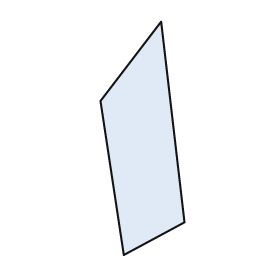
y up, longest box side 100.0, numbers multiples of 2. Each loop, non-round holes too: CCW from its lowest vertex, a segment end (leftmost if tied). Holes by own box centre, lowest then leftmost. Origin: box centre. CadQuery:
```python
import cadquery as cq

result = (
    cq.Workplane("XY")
    .moveTo(-8.0, -50.0)
    .lineTo(18.0, -36.0)
    .lineTo(8.0, 50.0)
    .lineTo(-18.0, 16.0)
    .close()
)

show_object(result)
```